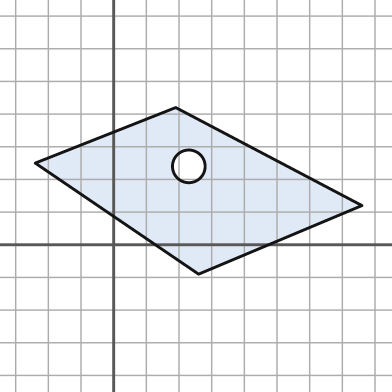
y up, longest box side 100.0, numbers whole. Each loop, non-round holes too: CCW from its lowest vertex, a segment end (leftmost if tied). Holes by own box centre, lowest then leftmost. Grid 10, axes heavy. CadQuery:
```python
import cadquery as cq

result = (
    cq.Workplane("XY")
    .moveTo(26.0, -9.0)
    .lineTo(76.0, 12.0)
    .lineTo(19.0, 42.0)
    .lineTo(-24.0, 25.0)
    .close()
    .moveTo(23.0, 24.0)
    .circle(5.0)
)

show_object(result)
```